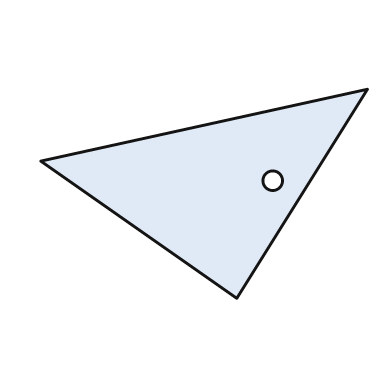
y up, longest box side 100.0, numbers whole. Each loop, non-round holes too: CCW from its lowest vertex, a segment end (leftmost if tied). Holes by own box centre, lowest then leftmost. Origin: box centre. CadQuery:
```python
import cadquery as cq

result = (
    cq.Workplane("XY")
    .moveTo(10.0, -32.0)
    .lineTo(50.0, 32.0)
    .lineTo(-50.0, 10.0)
    .close()
    .moveTo(21.0, 4.0)
    .circle(3.0)
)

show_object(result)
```